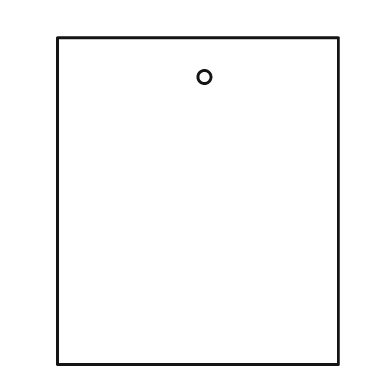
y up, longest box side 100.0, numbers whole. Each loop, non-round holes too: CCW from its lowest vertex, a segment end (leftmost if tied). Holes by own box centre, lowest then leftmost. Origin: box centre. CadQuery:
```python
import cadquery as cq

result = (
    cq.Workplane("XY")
    .moveTo(-43.0, -50.0)
    .lineTo(43.0, -50.0)
    .lineTo(43.0, 50.0)
    .lineTo(-43.0, 50.0)
    .close()
    .moveTo(2.0, 38.0)
    .circle(2.0)
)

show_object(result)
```